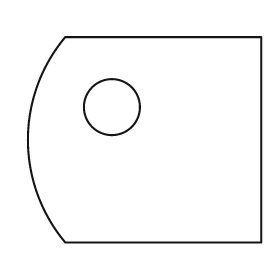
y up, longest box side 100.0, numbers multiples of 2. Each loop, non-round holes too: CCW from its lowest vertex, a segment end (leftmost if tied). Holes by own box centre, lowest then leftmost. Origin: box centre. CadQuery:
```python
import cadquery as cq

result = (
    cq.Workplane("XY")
    .moveTo(-34.0, -44.0)
    .lineTo(50.0, -44.0)
    .lineTo(50.0, 44.0)
    .lineTo(-34.0, 44.0)
    .threePointArc((-50.0, 0.0), (-34.0, -44.0))
    .close()
    .moveTo(-14.0, 14.0)
    .circle(12.0)
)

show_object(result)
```